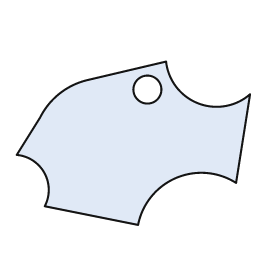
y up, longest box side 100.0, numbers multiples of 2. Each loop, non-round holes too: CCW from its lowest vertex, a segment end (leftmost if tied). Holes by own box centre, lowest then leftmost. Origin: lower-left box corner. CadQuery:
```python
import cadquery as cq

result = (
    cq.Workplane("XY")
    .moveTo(52.0, 0.0)
    .threePointArc((68.0, 20.0), (94.0, 18.0))
    .lineTo(100.0, 56.0)
    .threePointArc((78.0, 52.0), (64.0, 70.0))
    .lineTo(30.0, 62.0)
    .threePointArc((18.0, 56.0), (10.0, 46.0))
    .lineTo(0.0, 30.0)
    .threePointArc((12.0, 22.0), (12.0, 8.0))
    .close()
    .moveTo(56.0, 58.0)
    .circle(6.0)
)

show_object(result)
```